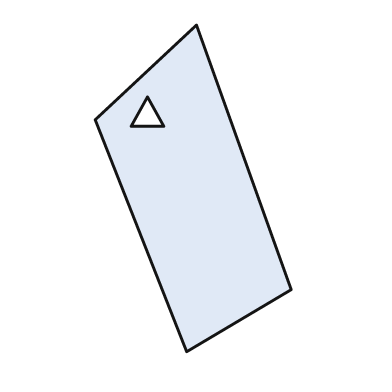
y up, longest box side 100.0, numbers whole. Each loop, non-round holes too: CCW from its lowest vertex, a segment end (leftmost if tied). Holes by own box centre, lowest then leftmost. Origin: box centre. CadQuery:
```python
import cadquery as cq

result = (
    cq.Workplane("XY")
    .moveTo(-2.0, -50.0)
    .lineTo(30.0, -31.0)
    .lineTo(1.0, 50.0)
    .lineTo(-30.0, 21.0)
    .close()
    .moveTo(-19.0, 19.0)
    .lineTo(-9.0, 19.0)
    .lineTo(-14.0, 28.0)
    .close()
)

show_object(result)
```